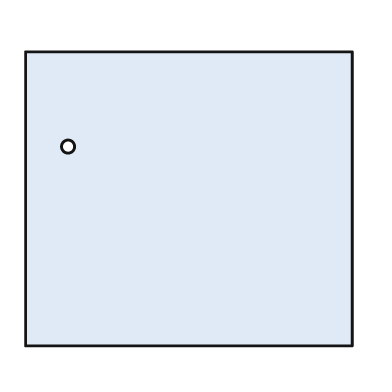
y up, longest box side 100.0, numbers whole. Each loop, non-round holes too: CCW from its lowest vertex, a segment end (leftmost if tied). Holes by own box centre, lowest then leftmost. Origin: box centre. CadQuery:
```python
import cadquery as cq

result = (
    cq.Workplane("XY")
    .moveTo(-50.0, -45.0)
    .lineTo(50.0, -45.0)
    .lineTo(50.0, 45.0)
    .lineTo(-50.0, 45.0)
    .close()
    .moveTo(-37.0, 16.0)
    .circle(2.0)
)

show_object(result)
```